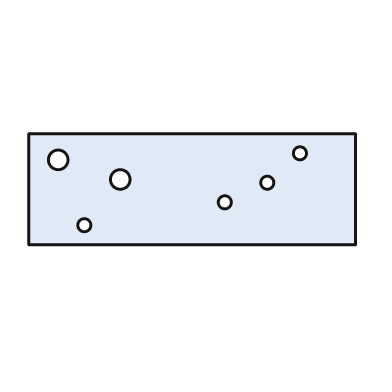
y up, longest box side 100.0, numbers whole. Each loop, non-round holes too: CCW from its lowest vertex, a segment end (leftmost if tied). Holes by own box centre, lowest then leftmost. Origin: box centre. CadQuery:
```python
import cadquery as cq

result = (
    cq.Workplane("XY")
    .moveTo(-50.0, -17.0)
    .lineTo(50.0, -17.0)
    .lineTo(50.0, 17.0)
    .lineTo(-50.0, 17.0)
    .close()
    .moveTo(-33.0, -11.0)
    .circle(2.0)
    .moveTo(10.0, -4.0)
    .circle(2.0)
    .moveTo(23.0, 2.0)
    .circle(2.0)
    .moveTo(-22.0, 3.0)
    .circle(3.0)
    .moveTo(-41.0, 9.0)
    .circle(3.0)
    .moveTo(33.0, 11.0)
    .circle(2.0)
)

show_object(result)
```